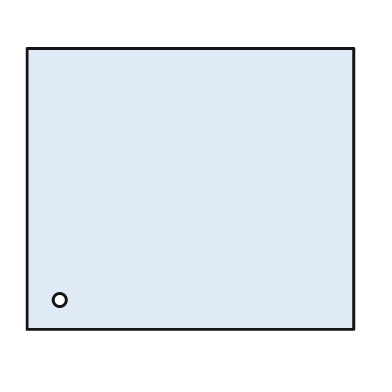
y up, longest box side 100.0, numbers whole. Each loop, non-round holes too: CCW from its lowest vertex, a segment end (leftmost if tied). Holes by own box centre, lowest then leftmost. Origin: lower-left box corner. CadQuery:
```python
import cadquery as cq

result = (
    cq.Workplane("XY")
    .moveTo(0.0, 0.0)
    .lineTo(100.0, 0.0)
    .lineTo(100.0, 86.0)
    .lineTo(0.0, 86.0)
    .close()
    .moveTo(10.0, 9.0)
    .circle(2.0)
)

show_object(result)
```